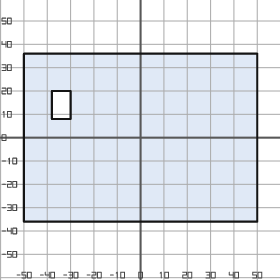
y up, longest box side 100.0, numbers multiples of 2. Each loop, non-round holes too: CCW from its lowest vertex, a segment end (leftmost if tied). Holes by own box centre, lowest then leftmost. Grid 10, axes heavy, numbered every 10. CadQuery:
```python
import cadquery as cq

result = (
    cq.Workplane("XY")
    .moveTo(-50.0, -36.0)
    .lineTo(50.0, -36.0)
    .lineTo(50.0, 36.0)
    .lineTo(-50.0, 36.0)
    .close()
    .moveTo(-38.0, 8.0)
    .lineTo(-30.0, 8.0)
    .lineTo(-30.0, 20.0)
    .lineTo(-38.0, 20.0)
    .close()
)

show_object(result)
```